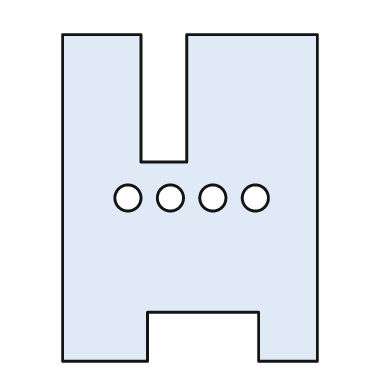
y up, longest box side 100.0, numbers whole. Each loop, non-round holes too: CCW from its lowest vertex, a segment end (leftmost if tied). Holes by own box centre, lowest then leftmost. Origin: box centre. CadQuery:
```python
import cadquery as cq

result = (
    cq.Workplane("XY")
    .moveTo(-39.0, -50.0)
    .lineTo(-13.0, -50.0)
    .lineTo(-13.0, -35.0)
    .lineTo(21.0, -35.0)
    .lineTo(21.0, -50.0)
    .lineTo(39.0, -50.0)
    .lineTo(39.0, 50.0)
    .lineTo(-1.0, 50.0)
    .lineTo(-1.0, 11.0)
    .lineTo(-15.0, 11.0)
    .lineTo(-15.0, 50.0)
    .lineTo(-39.0, 50.0)
    .close()
    .moveTo(-19.0, 0.0)
    .circle(4.0)
    .moveTo(-6.0, 0.0)
    .circle(4.0)
    .moveTo(7.0, 0.0)
    .circle(4.0)
    .moveTo(20.0, 0.0)
    .circle(4.0)
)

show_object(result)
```